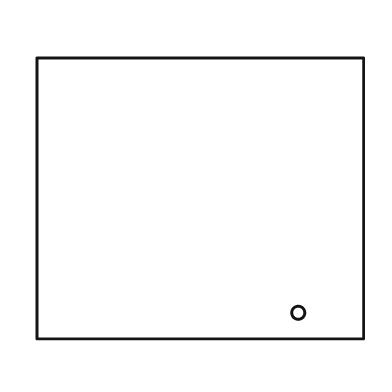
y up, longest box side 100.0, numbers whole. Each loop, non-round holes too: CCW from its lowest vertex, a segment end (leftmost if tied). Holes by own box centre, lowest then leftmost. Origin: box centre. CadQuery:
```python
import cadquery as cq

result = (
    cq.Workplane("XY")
    .moveTo(-50.0, -43.0)
    .lineTo(50.0, -43.0)
    .lineTo(50.0, 43.0)
    .lineTo(-50.0, 43.0)
    .close()
    .moveTo(30.0, -35.0)
    .circle(2.0)
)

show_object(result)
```